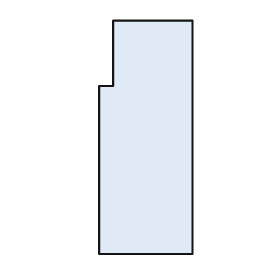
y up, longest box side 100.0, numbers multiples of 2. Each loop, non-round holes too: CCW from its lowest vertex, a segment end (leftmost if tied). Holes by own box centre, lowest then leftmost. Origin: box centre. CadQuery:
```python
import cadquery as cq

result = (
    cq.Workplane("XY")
    .moveTo(-20.0, -50.0)
    .lineTo(20.0, -50.0)
    .lineTo(20.0, 50.0)
    .lineTo(-14.0, 50.0)
    .lineTo(-14.0, 22.0)
    .lineTo(-20.0, 22.0)
    .close()
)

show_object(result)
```